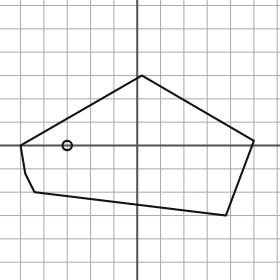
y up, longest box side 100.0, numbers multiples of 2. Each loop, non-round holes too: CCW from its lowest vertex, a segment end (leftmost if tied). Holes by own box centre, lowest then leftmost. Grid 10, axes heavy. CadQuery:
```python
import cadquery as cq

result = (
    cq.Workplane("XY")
    .moveTo(38.0, -30.0)
    .lineTo(50.0, 2.0)
    .lineTo(2.0, 30.0)
    .lineTo(-50.0, 0.0)
    .lineTo(-48.0, -12.0)
    .lineTo(-44.0, -20.0)
    .close()
    .moveTo(-30.0, 0.0)
    .circle(2.0)
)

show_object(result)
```